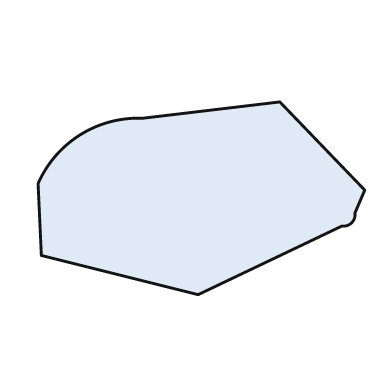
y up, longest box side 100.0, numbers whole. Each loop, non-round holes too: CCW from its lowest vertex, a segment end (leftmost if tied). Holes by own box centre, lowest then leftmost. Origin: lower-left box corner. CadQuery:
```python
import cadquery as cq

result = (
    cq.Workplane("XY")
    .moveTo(49.0, 0.0)
    .lineTo(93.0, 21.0)
    .threePointArc((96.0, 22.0), (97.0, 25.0))
    .lineTo(100.0, 32.0)
    .lineTo(74.0, 59.0)
    .lineTo(32.0, 54.0)
    .threePointArc((13.0, 49.0), (0.0, 34.0))
    .lineTo(1.0, 12.0)
    .close()
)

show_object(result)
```